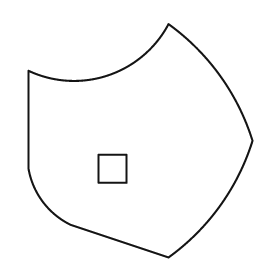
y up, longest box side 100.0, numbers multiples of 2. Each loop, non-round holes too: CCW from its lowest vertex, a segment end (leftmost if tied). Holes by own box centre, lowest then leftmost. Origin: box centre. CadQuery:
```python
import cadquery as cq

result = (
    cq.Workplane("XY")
    .moveTo(12.0, -50.0)
    .threePointArc((34.0, -28.0), (48.0, 0.0))
    .threePointArc((34.0, 28.0), (12.0, 50.0))
    .threePointArc((-14.0, 28.0), (-48.0, 30.0))
    .lineTo(-48.0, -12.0)
    .threePointArc((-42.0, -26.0), (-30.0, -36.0))
    .close()
    .moveTo(-18.0, -18.0)
    .lineTo(-6.0, -18.0)
    .lineTo(-6.0, -6.0)
    .lineTo(-18.0, -6.0)
    .close()
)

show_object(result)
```